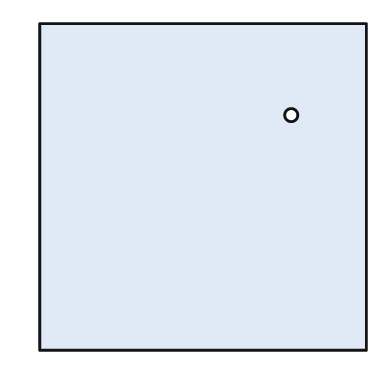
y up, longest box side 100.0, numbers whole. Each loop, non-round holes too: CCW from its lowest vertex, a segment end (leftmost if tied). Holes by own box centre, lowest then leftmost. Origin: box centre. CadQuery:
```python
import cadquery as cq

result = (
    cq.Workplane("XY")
    .moveTo(-50.0, -50.0)
    .lineTo(50.0, -50.0)
    .lineTo(50.0, 50.0)
    .lineTo(-50.0, 50.0)
    .close()
    .moveTo(27.0, 22.0)
    .circle(2.0)
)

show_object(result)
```